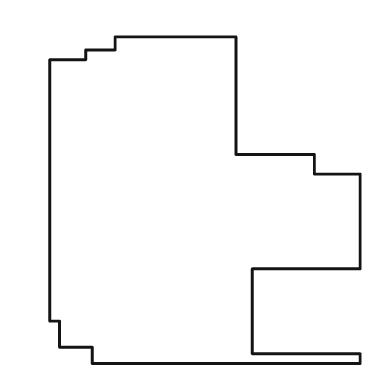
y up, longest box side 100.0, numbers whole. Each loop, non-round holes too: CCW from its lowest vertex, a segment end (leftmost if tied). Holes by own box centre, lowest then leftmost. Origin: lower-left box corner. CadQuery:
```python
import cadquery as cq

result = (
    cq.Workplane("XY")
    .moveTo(13.0, 0.0)
    .lineTo(95.0, 0.0)
    .lineTo(95.0, 3.0)
    .lineTo(62.0, 3.0)
    .lineTo(62.0, 29.0)
    .lineTo(95.0, 29.0)
    .lineTo(95.0, 58.0)
    .lineTo(81.0, 58.0)
    .lineTo(81.0, 64.0)
    .lineTo(57.0, 64.0)
    .lineTo(57.0, 100.0)
    .lineTo(20.0, 100.0)
    .lineTo(20.0, 96.0)
    .lineTo(11.0, 96.0)
    .lineTo(11.0, 93.0)
    .lineTo(0.0, 93.0)
    .lineTo(0.0, 13.0)
    .lineTo(3.0, 13.0)
    .lineTo(3.0, 5.0)
    .lineTo(13.0, 5.0)
    .close()
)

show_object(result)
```